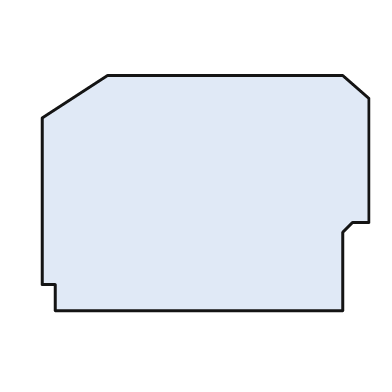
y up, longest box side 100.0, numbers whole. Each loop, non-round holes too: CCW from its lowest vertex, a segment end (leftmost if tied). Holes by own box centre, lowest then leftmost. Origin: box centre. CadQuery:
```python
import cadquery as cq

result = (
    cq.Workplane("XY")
    .moveTo(-46.0, -36.0)
    .lineTo(42.0, -36.0)
    .lineTo(42.0, -12.0)
    .lineTo(45.0, -9.0)
    .lineTo(50.0, -9.0)
    .lineTo(50.0, 29.0)
    .lineTo(42.0, 36.0)
    .lineTo(-30.0, 36.0)
    .lineTo(-50.0, 23.0)
    .lineTo(-50.0, -28.0)
    .lineTo(-46.0, -28.0)
    .close()
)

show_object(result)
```